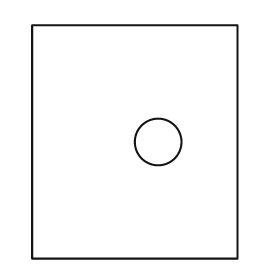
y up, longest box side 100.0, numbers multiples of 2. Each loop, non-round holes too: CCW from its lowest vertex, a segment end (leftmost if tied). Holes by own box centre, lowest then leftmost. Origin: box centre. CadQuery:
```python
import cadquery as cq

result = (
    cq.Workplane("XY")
    .moveTo(-44.0, -50.0)
    .lineTo(44.0, -50.0)
    .lineTo(44.0, 50.0)
    .lineTo(-44.0, 50.0)
    .close()
    .moveTo(10.0, 0.0)
    .circle(10.0)
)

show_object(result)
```